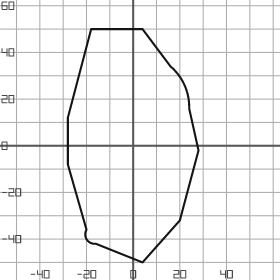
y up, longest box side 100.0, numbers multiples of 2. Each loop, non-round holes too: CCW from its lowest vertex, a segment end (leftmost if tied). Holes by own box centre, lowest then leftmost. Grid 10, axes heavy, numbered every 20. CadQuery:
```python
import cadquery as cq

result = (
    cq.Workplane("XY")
    .moveTo(4.0, -50.0)
    .lineTo(20.0, -32.0)
    .lineTo(28.0, -2.0)
    .lineTo(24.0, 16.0)
    .threePointArc((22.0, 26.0), (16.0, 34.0))
    .lineTo(4.0, 50.0)
    .lineTo(-18.0, 50.0)
    .lineTo(-28.0, 12.0)
    .lineTo(-28.0, -8.0)
    .lineTo(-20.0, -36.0)
    .threePointArc((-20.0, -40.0), (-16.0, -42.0))
    .close()
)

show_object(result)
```